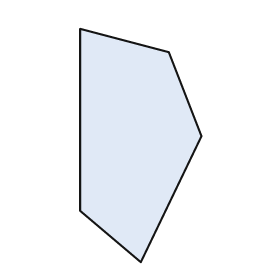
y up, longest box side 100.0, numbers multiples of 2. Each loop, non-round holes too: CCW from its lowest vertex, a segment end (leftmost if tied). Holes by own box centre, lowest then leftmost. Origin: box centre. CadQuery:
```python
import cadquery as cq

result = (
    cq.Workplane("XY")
    .moveTo(0.0, -50.0)
    .lineTo(26.0, 4.0)
    .lineTo(12.0, 40.0)
    .lineTo(-26.0, 50.0)
    .lineTo(-26.0, -28.0)
    .close()
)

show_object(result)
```